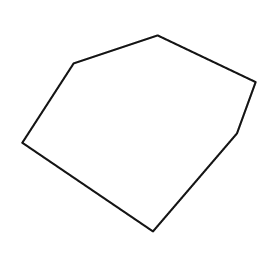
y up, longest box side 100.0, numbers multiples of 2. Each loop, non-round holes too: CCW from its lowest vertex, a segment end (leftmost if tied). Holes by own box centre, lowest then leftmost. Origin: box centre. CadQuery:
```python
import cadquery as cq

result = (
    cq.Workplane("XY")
    .moveTo(6.0, -42.0)
    .lineTo(42.0, 0.0)
    .lineTo(50.0, 22.0)
    .lineTo(8.0, 42.0)
    .lineTo(-28.0, 30.0)
    .lineTo(-50.0, -4.0)
    .close()
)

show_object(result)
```